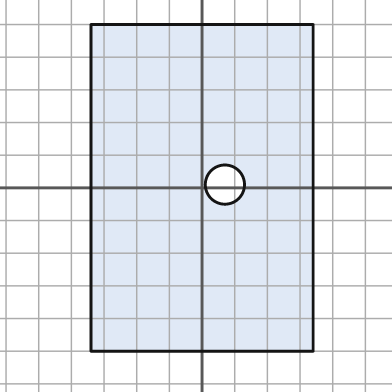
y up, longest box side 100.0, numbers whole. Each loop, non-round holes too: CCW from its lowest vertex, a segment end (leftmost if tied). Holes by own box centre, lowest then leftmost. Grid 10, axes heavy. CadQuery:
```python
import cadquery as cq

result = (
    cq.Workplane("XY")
    .moveTo(-34.0, -50.0)
    .lineTo(34.0, -50.0)
    .lineTo(34.0, 50.0)
    .lineTo(-34.0, 50.0)
    .close()
    .moveTo(7.0, 1.0)
    .circle(6.0)
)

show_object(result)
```